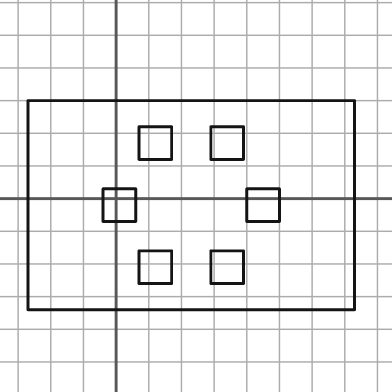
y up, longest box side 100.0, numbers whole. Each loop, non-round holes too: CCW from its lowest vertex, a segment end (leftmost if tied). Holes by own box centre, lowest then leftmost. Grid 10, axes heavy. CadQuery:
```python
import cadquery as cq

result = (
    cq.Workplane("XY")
    .moveTo(-27.0, -34.0)
    .lineTo(73.0, -34.0)
    .lineTo(73.0, 30.0)
    .lineTo(-27.0, 30.0)
    .close()
    .moveTo(7.0, -26.0)
    .lineTo(17.0, -26.0)
    .lineTo(17.0, -16.0)
    .lineTo(7.0, -16.0)
    .close()
    .moveTo(29.0, -26.0)
    .lineTo(39.0, -26.0)
    .lineTo(39.0, -16.0)
    .lineTo(29.0, -16.0)
    .close()
    .moveTo(-4.0, -7.0)
    .lineTo(6.0, -7.0)
    .lineTo(6.0, 3.0)
    .lineTo(-4.0, 3.0)
    .close()
    .moveTo(40.0, -7.0)
    .lineTo(50.0, -7.0)
    .lineTo(50.0, 3.0)
    .lineTo(40.0, 3.0)
    .close()
    .moveTo(7.0, 12.0)
    .lineTo(17.0, 12.0)
    .lineTo(17.0, 22.0)
    .lineTo(7.0, 22.0)
    .close()
    .moveTo(29.0, 12.0)
    .lineTo(39.0, 12.0)
    .lineTo(39.0, 22.0)
    .lineTo(29.0, 22.0)
    .close()
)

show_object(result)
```